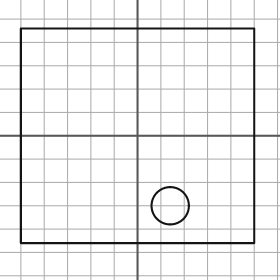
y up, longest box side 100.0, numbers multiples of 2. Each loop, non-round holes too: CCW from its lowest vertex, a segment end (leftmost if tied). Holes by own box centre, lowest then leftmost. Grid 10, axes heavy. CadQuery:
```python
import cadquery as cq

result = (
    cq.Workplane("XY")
    .moveTo(-50.0, -46.0)
    .lineTo(50.0, -46.0)
    .lineTo(50.0, 46.0)
    .lineTo(-50.0, 46.0)
    .close()
    .moveTo(14.0, -30.0)
    .circle(8.0)
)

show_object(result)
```